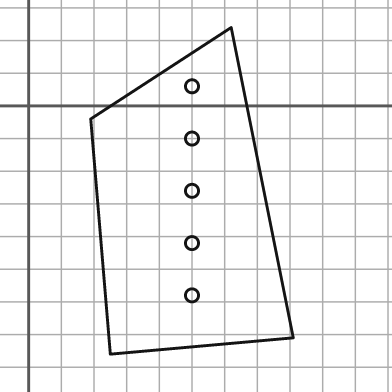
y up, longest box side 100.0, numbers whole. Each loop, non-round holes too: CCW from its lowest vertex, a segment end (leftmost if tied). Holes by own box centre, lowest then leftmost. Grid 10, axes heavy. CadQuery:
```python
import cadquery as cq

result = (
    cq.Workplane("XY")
    .moveTo(25.0, -76.0)
    .lineTo(81.0, -71.0)
    .lineTo(62.0, 24.0)
    .lineTo(19.0, -4.0)
    .close()
    .moveTo(50.0, -58.0)
    .circle(2.0)
    .moveTo(50.0, -42.0)
    .circle(2.0)
    .moveTo(50.0, -26.0)
    .circle(2.0)
    .moveTo(50.0, -10.0)
    .circle(2.0)
    .moveTo(50.0, 6.0)
    .circle(2.0)
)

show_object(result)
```